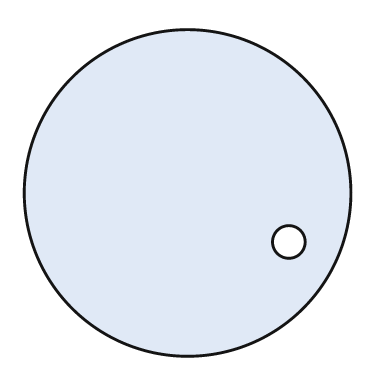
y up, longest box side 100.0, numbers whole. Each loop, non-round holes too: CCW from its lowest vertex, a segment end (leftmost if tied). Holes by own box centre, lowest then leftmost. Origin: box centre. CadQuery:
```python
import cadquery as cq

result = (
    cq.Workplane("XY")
    .moveTo(0.0, 0.0)
    .circle(50.0)
    .moveTo(31.0, -15.0)
    .circle(5.0)
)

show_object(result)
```